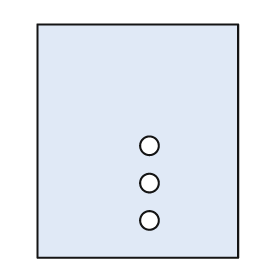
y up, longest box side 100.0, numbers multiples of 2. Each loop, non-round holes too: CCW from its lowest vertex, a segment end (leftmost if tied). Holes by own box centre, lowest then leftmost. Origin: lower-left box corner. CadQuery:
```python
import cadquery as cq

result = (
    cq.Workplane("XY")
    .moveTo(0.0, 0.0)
    .lineTo(86.0, 0.0)
    .lineTo(86.0, 100.0)
    .lineTo(0.0, 100.0)
    .close()
    .moveTo(48.0, 16.0)
    .circle(4.0)
    .moveTo(48.0, 32.0)
    .circle(4.0)
    .moveTo(48.0, 48.0)
    .circle(4.0)
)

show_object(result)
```